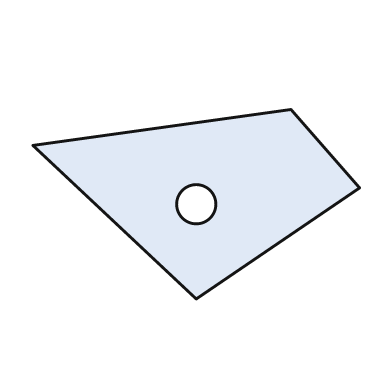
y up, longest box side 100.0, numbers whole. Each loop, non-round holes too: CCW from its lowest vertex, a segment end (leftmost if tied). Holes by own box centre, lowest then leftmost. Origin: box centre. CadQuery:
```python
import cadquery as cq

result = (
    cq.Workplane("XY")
    .moveTo(0.0, -29.0)
    .lineTo(50.0, 5.0)
    .lineTo(29.0, 29.0)
    .lineTo(-50.0, 18.0)
    .close()
    .moveTo(0.0, 0.0)
    .circle(6.0)
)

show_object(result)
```